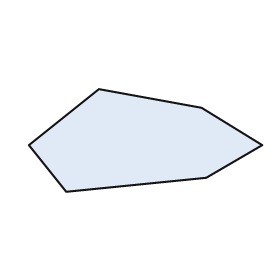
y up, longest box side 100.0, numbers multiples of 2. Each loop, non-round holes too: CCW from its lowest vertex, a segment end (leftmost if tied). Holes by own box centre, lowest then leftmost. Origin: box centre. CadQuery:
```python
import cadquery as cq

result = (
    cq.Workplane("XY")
    .moveTo(-34.0, -22.0)
    .lineTo(26.0, -16.0)
    .lineTo(50.0, -2.0)
    .lineTo(24.0, 14.0)
    .lineTo(-20.0, 22.0)
    .lineTo(-50.0, -2.0)
    .close()
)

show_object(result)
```